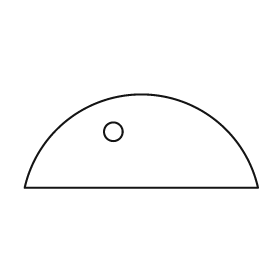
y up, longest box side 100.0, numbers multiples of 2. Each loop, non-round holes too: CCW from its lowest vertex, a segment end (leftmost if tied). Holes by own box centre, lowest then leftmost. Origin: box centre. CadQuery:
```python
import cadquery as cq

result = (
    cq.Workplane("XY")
    .moveTo(-50.0, -20.0)
    .lineTo(50.0, -20.0)
    .threePointArc((0.0, 20.0), (-50.0, -20.0))
    .close()
    .moveTo(-12.0, 4.0)
    .circle(4.0)
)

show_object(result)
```